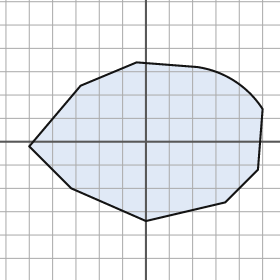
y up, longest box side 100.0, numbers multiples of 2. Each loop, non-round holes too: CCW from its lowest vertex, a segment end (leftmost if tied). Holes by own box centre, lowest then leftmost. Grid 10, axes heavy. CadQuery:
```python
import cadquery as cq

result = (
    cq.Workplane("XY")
    .moveTo(0.0, -34.0)
    .lineTo(34.0, -26.0)
    .lineTo(48.0, -12.0)
    .lineTo(50.0, 14.0)
    .threePointArc((38.0, 26.0), (22.0, 32.0))
    .lineTo(-4.0, 34.0)
    .lineTo(-28.0, 24.0)
    .lineTo(-50.0, -2.0)
    .lineTo(-32.0, -20.0)
    .close()
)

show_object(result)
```